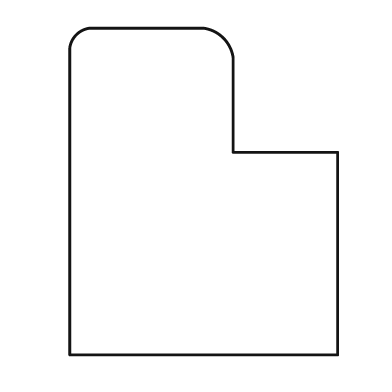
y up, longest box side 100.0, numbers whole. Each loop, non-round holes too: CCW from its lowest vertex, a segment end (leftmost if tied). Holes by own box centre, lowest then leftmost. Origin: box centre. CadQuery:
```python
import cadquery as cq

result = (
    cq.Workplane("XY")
    .moveTo(-41.0, -50.0)
    .lineTo(41.0, -50.0)
    .lineTo(41.0, 12.0)
    .lineTo(9.0, 12.0)
    .lineTo(9.0, 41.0)
    .threePointArc((6.0, 47.0), (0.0, 50.0))
    .lineTo(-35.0, 50.0)
    .threePointArc((-39.0, 48.0), (-41.0, 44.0))
    .close()
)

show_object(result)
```